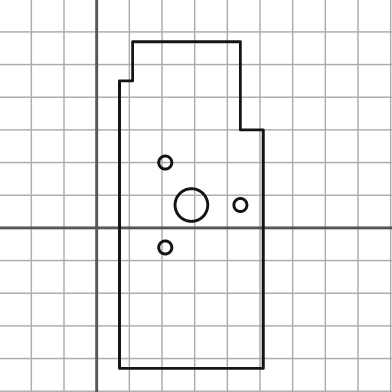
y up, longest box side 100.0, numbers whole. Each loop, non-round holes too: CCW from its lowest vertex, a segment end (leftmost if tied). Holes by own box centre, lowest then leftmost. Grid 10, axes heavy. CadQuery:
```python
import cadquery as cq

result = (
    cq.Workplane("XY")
    .moveTo(7.0, -43.0)
    .lineTo(51.0, -43.0)
    .lineTo(51.0, 30.0)
    .lineTo(44.0, 30.0)
    .lineTo(44.0, 57.0)
    .lineTo(11.0, 57.0)
    .lineTo(11.0, 45.0)
    .lineTo(7.0, 45.0)
    .close()
    .moveTo(21.0, -6.0)
    .circle(2.0)
    .moveTo(29.0, 7.0)
    .circle(5.0)
    .moveTo(44.0, 7.0)
    .circle(2.0)
    .moveTo(21.0, 20.0)
    .circle(2.0)
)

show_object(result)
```